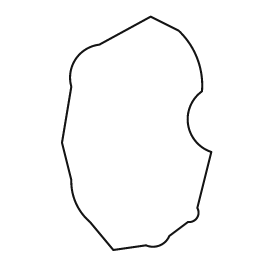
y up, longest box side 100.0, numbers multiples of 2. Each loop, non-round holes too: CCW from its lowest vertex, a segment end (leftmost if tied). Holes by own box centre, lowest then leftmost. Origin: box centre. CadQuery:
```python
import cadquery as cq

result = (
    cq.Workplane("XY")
    .moveTo(-10.0, -50.0)
    .lineTo(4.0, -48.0)
    .threePointArc((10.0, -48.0), (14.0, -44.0))
    .lineTo(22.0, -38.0)
    .threePointArc((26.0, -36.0), (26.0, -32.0))
    .lineTo(32.0, -8.0)
    .threePointArc((22.0, 4.0), (28.0, 18.0))
    .threePointArc((26.0, 32.0), (18.0, 44.0))
    .lineTo(6.0, 50.0)
    .lineTo(-16.0, 38.0)
    .threePointArc((-26.0, 32.0), (-28.0, 20.0))
    .lineTo(-32.0, -4.0)
    .lineTo(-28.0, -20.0)
    .threePointArc((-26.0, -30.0), (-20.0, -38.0))
    .close()
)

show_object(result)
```